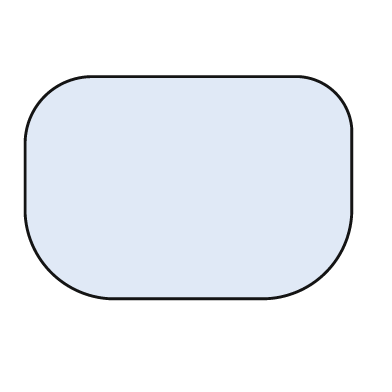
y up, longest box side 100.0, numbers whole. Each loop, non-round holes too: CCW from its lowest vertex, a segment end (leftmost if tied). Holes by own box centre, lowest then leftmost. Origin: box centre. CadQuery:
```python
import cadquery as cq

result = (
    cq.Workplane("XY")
    .moveTo(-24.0, -34.0)
    .lineTo(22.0, -34.0)
    .threePointArc((42.0, -26.0), (50.0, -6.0))
    .lineTo(50.0, 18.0)
    .threePointArc((45.0, 29.0), (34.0, 34.0))
    .lineTo(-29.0, 34.0)
    .threePointArc((-44.0, 28.0), (-50.0, 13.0))
    .lineTo(-50.0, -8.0)
    .threePointArc((-42.0, -26.0), (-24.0, -34.0))
    .close()
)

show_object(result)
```